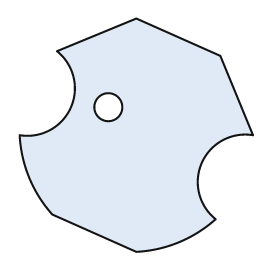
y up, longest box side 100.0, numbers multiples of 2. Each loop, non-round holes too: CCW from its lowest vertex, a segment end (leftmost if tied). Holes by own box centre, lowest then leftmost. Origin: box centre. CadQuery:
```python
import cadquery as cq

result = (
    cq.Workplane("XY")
    .moveTo(0.0, -50.0)
    .threePointArc((18.0, -46.0), (34.0, -36.0))
    .threePointArc((28.0, -12.0), (50.0, 0.0))
    .lineTo(36.0, 34.0)
    .lineTo(0.0, 50.0)
    .lineTo(-34.0, 36.0)
    .threePointArc((-28.0, 12.0), (-50.0, 0.0))
    .threePointArc((-46.0, -18.0), (-36.0, -34.0))
    .close()
    .moveTo(-12.0, 12.0)
    .circle(6.0)
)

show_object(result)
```